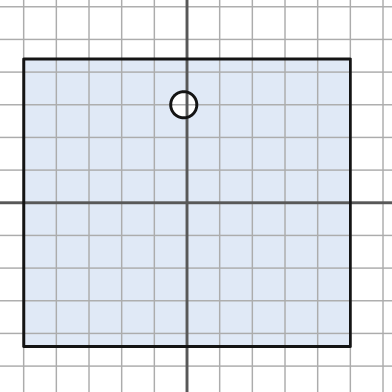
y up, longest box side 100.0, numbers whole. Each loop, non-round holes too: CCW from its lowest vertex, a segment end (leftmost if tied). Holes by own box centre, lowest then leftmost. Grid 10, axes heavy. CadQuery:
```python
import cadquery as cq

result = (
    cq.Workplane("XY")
    .moveTo(-50.0, -44.0)
    .lineTo(50.0, -44.0)
    .lineTo(50.0, 44.0)
    .lineTo(-50.0, 44.0)
    .close()
    .moveTo(-1.0, 30.0)
    .circle(4.0)
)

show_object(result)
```